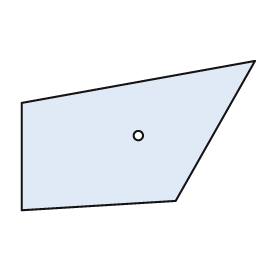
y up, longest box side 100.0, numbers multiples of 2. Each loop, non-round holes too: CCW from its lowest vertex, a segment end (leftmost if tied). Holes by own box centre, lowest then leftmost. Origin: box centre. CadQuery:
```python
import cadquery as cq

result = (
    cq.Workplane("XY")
    .moveTo(-50.0, -32.0)
    .lineTo(16.0, -28.0)
    .lineTo(50.0, 32.0)
    .lineTo(-50.0, 14.0)
    .close()
    .moveTo(0.0, 0.0)
    .circle(2.0)
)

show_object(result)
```